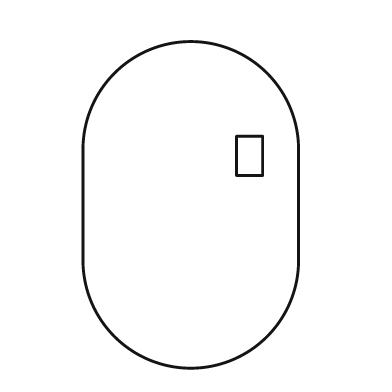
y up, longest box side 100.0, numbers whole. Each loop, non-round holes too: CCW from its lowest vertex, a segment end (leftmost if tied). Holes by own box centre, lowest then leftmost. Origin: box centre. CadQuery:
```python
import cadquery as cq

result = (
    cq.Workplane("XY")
    .moveTo(-33.0, -17.0)
    .threePointArc((0.0, -50.0), (33.0, -17.0))
    .lineTo(33.0, 17.0)
    .threePointArc((0.0, 50.0), (-33.0, 17.0))
    .close()
    .moveTo(14.0, 9.0)
    .lineTo(22.0, 9.0)
    .lineTo(22.0, 21.0)
    .lineTo(14.0, 21.0)
    .close()
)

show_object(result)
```